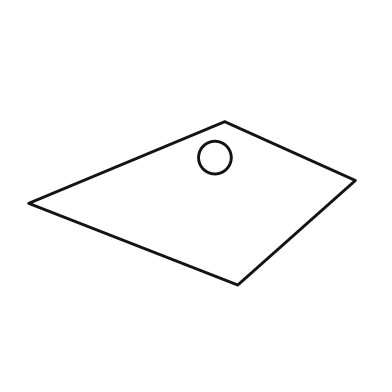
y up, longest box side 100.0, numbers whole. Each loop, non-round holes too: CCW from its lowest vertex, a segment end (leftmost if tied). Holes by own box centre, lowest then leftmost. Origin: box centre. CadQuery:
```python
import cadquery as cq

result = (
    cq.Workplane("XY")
    .moveTo(14.0, -25.0)
    .lineTo(50.0, 7.0)
    .lineTo(10.0, 25.0)
    .lineTo(-50.0, 0.0)
    .close()
    .moveTo(7.0, 14.0)
    .circle(5.0)
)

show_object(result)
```